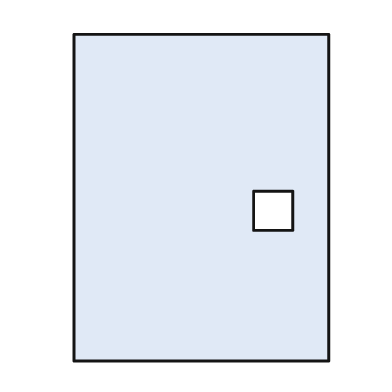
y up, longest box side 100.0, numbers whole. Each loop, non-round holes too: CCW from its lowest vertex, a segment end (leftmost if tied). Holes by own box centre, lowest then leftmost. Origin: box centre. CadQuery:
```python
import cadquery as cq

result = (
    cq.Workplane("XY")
    .moveTo(-39.0, -50.0)
    .lineTo(39.0, -50.0)
    .lineTo(39.0, 50.0)
    .lineTo(-39.0, 50.0)
    .close()
    .moveTo(16.0, -10.0)
    .lineTo(28.0, -10.0)
    .lineTo(28.0, 2.0)
    .lineTo(16.0, 2.0)
    .close()
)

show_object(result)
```